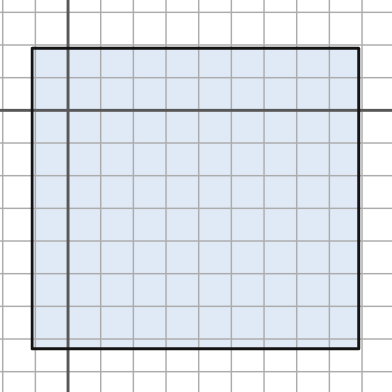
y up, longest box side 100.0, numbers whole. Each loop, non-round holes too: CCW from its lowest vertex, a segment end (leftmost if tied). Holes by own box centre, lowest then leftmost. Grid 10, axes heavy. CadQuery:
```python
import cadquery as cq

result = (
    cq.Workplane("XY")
    .moveTo(-11.0, -73.0)
    .lineTo(89.0, -73.0)
    .lineTo(89.0, 19.0)
    .lineTo(-11.0, 19.0)
    .close()
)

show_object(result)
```